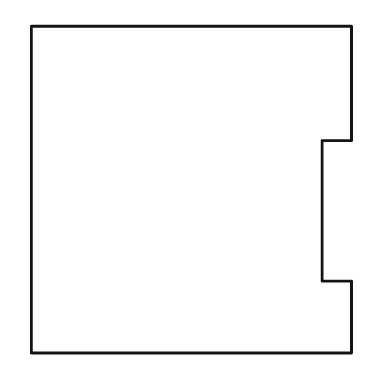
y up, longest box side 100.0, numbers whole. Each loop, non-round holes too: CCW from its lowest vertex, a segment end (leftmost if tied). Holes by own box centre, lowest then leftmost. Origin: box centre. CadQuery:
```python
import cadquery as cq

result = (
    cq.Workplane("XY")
    .moveTo(-49.0, -50.0)
    .lineTo(49.0, -50.0)
    .lineTo(49.0, -28.0)
    .lineTo(40.0, -28.0)
    .lineTo(40.0, 15.0)
    .lineTo(49.0, 15.0)
    .lineTo(49.0, 50.0)
    .lineTo(-49.0, 50.0)
    .close()
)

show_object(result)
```